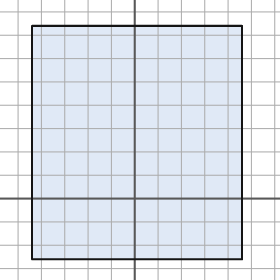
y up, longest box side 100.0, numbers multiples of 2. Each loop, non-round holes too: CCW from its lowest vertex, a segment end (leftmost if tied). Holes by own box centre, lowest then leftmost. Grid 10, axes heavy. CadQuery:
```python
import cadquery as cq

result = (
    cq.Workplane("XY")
    .moveTo(-44.0, -26.0)
    .lineTo(46.0, -26.0)
    .lineTo(46.0, 74.0)
    .lineTo(-44.0, 74.0)
    .close()
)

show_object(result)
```